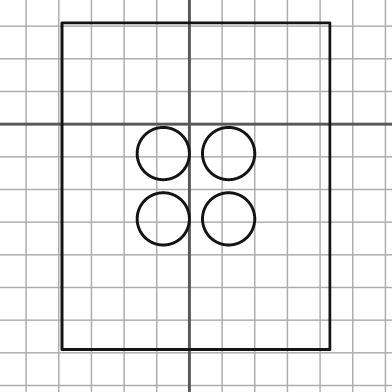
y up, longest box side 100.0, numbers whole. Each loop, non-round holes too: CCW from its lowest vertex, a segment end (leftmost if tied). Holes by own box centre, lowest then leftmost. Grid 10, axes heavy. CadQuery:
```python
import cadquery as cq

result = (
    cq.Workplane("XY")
    .moveTo(-39.0, -69.0)
    .lineTo(43.0, -69.0)
    .lineTo(43.0, 31.0)
    .lineTo(-39.0, 31.0)
    .close()
    .moveTo(-8.0, -29.0)
    .circle(8.0)
    .moveTo(12.0, -29.0)
    .circle(8.0)
    .moveTo(-8.0, -9.0)
    .circle(8.0)
    .moveTo(12.0, -9.0)
    .circle(8.0)
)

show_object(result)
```